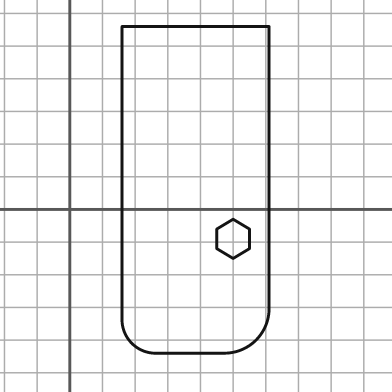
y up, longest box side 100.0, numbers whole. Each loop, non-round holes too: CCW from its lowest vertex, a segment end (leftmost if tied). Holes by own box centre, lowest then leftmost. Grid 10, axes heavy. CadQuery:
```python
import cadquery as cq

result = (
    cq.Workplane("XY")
    .moveTo(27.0, -44.0)
    .lineTo(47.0, -44.0)
    .threePointArc((57.0, -40.0), (61.0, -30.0))
    .lineTo(61.0, 56.0)
    .lineTo(16.0, 56.0)
    .lineTo(16.0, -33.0)
    .threePointArc((19.0, -41.0), (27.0, -44.0))
    .close()
    .moveTo(50.0, -15.0)
    .lineTo(55.0, -12.0)
    .lineTo(55.0, -6.0)
    .lineTo(50.0, -3.0)
    .lineTo(45.0, -6.0)
    .lineTo(45.0, -12.0)
    .close()
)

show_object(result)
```